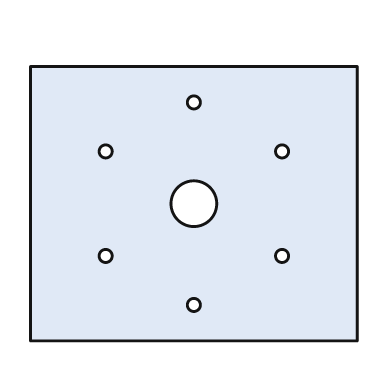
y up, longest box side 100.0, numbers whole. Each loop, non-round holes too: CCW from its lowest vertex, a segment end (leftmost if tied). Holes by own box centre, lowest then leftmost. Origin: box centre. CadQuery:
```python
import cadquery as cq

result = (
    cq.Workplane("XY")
    .moveTo(-50.0, -42.0)
    .lineTo(50.0, -42.0)
    .lineTo(50.0, 42.0)
    .lineTo(-50.0, 42.0)
    .close()
    .moveTo(0.0, -31.0)
    .circle(2.0)
    .moveTo(-27.0, -16.0)
    .circle(2.0)
    .moveTo(27.0, -16.0)
    .circle(2.0)
    .moveTo(0.0, 0.0)
    .circle(7.0)
    .moveTo(-27.0, 16.0)
    .circle(2.0)
    .moveTo(27.0, 16.0)
    .circle(2.0)
    .moveTo(0.0, 31.0)
    .circle(2.0)
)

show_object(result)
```